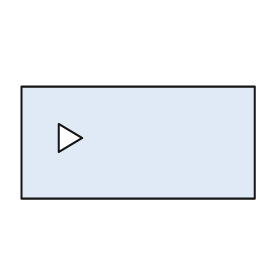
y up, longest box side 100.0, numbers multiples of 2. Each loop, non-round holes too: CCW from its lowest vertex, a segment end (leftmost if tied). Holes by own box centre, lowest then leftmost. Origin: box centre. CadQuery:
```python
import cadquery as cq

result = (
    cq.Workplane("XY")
    .moveTo(-50.0, -24.0)
    .lineTo(50.0, -24.0)
    .lineTo(50.0, 24.0)
    .lineTo(-50.0, 24.0)
    .close()
    .moveTo(-34.0, -4.0)
    .lineTo(-24.0, 2.0)
    .lineTo(-34.0, 8.0)
    .close()
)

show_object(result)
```